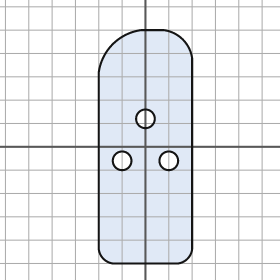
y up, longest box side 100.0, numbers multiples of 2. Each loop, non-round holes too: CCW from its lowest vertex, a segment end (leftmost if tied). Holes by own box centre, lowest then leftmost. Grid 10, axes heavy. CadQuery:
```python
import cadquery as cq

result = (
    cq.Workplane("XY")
    .moveTo(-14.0, -50.0)
    .lineTo(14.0, -50.0)
    .threePointArc((18.0, -48.0), (20.0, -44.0))
    .lineTo(20.0, 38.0)
    .threePointArc((16.0, 46.0), (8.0, 50.0))
    .lineTo(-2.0, 50.0)
    .threePointArc((-14.0, 44.0), (-20.0, 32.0))
    .lineTo(-20.0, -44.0)
    .threePointArc((-18.0, -48.0), (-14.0, -50.0))
    .close()
    .moveTo(-10.0, -6.0)
    .circle(4.0)
    .moveTo(10.0, -6.0)
    .circle(4.0)
    .moveTo(0.0, 12.0)
    .circle(4.0)
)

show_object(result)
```